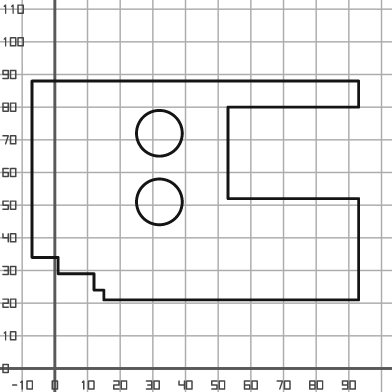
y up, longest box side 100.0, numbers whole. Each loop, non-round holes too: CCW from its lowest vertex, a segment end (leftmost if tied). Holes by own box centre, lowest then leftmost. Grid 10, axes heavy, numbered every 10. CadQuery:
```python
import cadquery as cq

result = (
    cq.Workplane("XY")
    .moveTo(15.0, 21.0)
    .lineTo(93.0, 21.0)
    .lineTo(93.0, 52.0)
    .lineTo(53.0, 52.0)
    .lineTo(53.0, 80.0)
    .lineTo(93.0, 80.0)
    .lineTo(93.0, 88.0)
    .lineTo(-7.0, 88.0)
    .lineTo(-7.0, 34.0)
    .lineTo(1.0, 34.0)
    .lineTo(1.0, 29.0)
    .lineTo(12.0, 29.0)
    .lineTo(12.0, 24.0)
    .lineTo(15.0, 24.0)
    .close()
    .moveTo(32.0, 51.0)
    .circle(7.0)
    .moveTo(32.0, 72.0)
    .circle(7.0)
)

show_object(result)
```